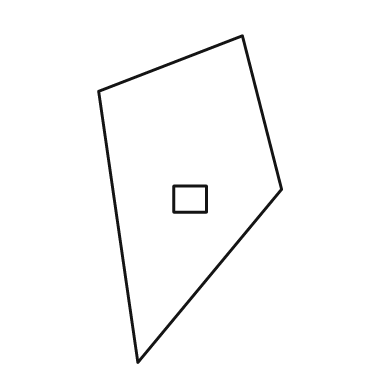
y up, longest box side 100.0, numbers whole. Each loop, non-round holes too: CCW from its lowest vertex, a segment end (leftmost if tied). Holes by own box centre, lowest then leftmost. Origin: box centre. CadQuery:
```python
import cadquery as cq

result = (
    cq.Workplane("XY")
    .moveTo(-16.0, -50.0)
    .lineTo(28.0, 3.0)
    .lineTo(16.0, 50.0)
    .lineTo(-28.0, 33.0)
    .close()
    .moveTo(-5.0, -4.0)
    .lineTo(5.0, -4.0)
    .lineTo(5.0, 4.0)
    .lineTo(-5.0, 4.0)
    .close()
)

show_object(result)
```